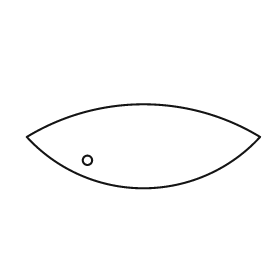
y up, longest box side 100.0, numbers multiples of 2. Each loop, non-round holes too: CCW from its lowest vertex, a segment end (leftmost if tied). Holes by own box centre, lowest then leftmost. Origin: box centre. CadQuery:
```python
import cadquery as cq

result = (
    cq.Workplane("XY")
    .moveTo(-50.0, 4.0)
    .threePointArc((0.0, -18.0), (50.0, 4.0))
    .threePointArc((0.0, 18.0), (-50.0, 4.0))
    .close()
    .moveTo(-24.0, -6.0)
    .circle(2.0)
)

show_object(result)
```